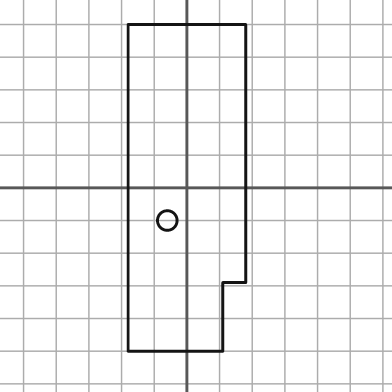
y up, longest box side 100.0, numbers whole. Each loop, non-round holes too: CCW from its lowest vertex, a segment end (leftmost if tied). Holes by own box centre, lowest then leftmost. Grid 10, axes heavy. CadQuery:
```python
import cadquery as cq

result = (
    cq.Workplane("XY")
    .moveTo(-18.0, -50.0)
    .lineTo(11.0, -50.0)
    .lineTo(11.0, -29.0)
    .lineTo(18.0, -29.0)
    .lineTo(18.0, 50.0)
    .lineTo(-18.0, 50.0)
    .close()
    .moveTo(-6.0, -10.0)
    .circle(3.0)
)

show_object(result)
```